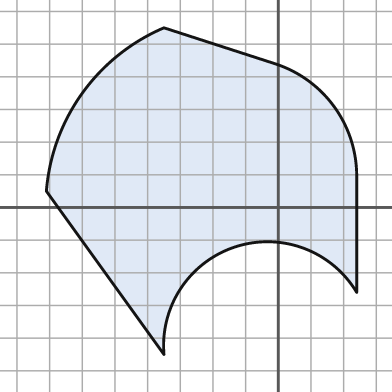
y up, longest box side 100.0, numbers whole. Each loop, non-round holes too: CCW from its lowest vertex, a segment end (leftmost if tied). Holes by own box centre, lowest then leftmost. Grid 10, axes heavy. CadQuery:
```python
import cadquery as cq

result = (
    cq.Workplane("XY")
    .moveTo(-35.0, -45.0)
    .threePointArc((-13.0, -12.0), (24.0, -26.0))
    .lineTo(24.0, 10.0)
    .threePointArc((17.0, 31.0), (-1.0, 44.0))
    .lineTo(-35.0, 55.0)
    .threePointArc((-60.0, 35.0), (-71.0, 5.0))
    .close()
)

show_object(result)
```